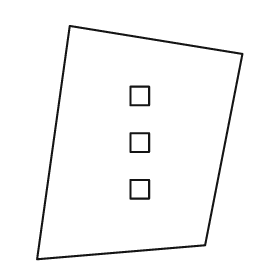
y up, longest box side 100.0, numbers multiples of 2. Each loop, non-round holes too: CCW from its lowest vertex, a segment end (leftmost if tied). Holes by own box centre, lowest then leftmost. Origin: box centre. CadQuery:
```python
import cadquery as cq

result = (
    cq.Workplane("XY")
    .moveTo(-44.0, -50.0)
    .lineTo(28.0, -44.0)
    .lineTo(44.0, 38.0)
    .lineTo(-30.0, 50.0)
    .close()
    .moveTo(-4.0, -24.0)
    .lineTo(4.0, -24.0)
    .lineTo(4.0, -16.0)
    .lineTo(-4.0, -16.0)
    .close()
    .moveTo(-4.0, -4.0)
    .lineTo(4.0, -4.0)
    .lineTo(4.0, 4.0)
    .lineTo(-4.0, 4.0)
    .close()
    .moveTo(-4.0, 16.0)
    .lineTo(4.0, 16.0)
    .lineTo(4.0, 24.0)
    .lineTo(-4.0, 24.0)
    .close()
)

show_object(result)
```